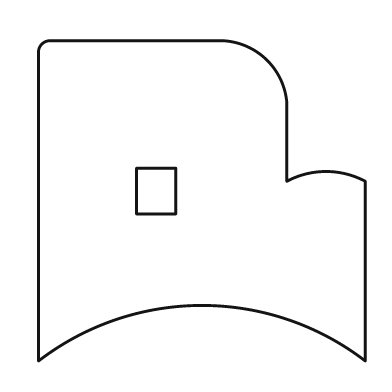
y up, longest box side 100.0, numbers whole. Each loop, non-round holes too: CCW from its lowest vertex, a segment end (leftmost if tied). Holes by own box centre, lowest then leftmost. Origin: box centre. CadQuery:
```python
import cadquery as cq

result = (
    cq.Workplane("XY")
    .moveTo(-50.0, -49.0)
    .threePointArc((0.0, -32.0), (50.0, -49.0))
    .lineTo(50.0, 6.0)
    .threePointArc((38.0, 9.0), (26.0, 6.0))
    .lineTo(26.0, 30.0)
    .threePointArc((20.0, 43.0), (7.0, 49.0))
    .lineTo(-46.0, 49.0)
    .threePointArc((-49.0, 48.0), (-50.0, 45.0))
    .close()
    .moveTo(-20.0, -4.0)
    .lineTo(-8.0, -4.0)
    .lineTo(-8.0, 10.0)
    .lineTo(-20.0, 10.0)
    .close()
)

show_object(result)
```